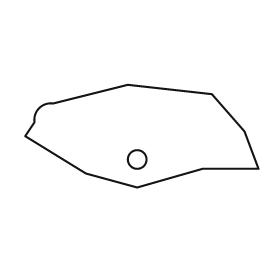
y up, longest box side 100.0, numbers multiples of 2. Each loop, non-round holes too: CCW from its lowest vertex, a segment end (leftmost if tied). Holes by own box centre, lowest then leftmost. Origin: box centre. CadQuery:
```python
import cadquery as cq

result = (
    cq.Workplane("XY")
    .moveTo(-2.0, -22.0)
    .lineTo(26.0, -14.0)
    .lineTo(50.0, -14.0)
    .lineTo(44.0, 2.0)
    .lineTo(30.0, 18.0)
    .lineTo(-6.0, 22.0)
    .lineTo(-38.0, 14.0)
    .threePointArc((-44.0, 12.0), (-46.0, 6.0))
    .lineTo(-50.0, 0.0)
    .lineTo(-24.0, -16.0)
    .close()
    .moveTo(-2.0, -10.0)
    .circle(4.0)
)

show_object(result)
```